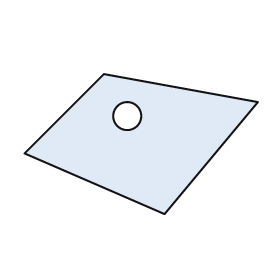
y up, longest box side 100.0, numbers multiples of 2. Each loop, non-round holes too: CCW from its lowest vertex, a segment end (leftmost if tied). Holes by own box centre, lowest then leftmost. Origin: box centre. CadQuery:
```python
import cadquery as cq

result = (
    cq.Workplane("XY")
    .moveTo(10.0, -30.0)
    .lineTo(50.0, 18.0)
    .lineTo(-16.0, 30.0)
    .lineTo(-50.0, -4.0)
    .close()
    .moveTo(-6.0, 12.0)
    .circle(6.0)
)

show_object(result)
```